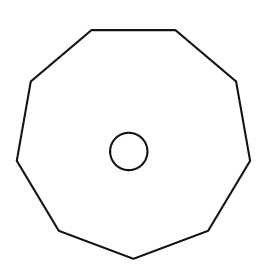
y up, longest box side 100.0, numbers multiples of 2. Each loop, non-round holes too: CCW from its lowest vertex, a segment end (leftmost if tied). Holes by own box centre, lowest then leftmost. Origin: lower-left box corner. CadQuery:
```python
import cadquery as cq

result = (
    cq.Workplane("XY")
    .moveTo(50.0, 0.0)
    .lineTo(82.0, 12.0)
    .lineTo(100.0, 42.0)
    .lineTo(94.0, 76.0)
    .lineTo(68.0, 98.0)
    .lineTo(32.0, 98.0)
    .lineTo(6.0, 76.0)
    .lineTo(0.0, 42.0)
    .lineTo(18.0, 12.0)
    .close()
    .moveTo(48.0, 46.0)
    .circle(8.0)
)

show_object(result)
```